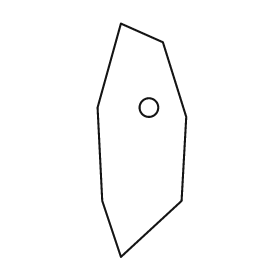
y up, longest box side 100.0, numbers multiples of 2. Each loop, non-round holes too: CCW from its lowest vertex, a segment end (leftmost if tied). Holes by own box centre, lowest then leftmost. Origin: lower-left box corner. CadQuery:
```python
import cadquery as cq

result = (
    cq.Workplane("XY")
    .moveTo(10.0, 0.0)
    .lineTo(36.0, 24.0)
    .lineTo(38.0, 60.0)
    .lineTo(28.0, 92.0)
    .lineTo(10.0, 100.0)
    .lineTo(0.0, 64.0)
    .lineTo(2.0, 24.0)
    .close()
    .moveTo(22.0, 64.0)
    .circle(4.0)
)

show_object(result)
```